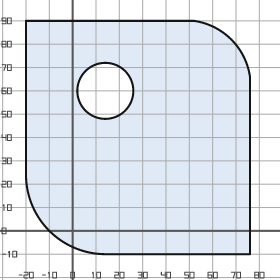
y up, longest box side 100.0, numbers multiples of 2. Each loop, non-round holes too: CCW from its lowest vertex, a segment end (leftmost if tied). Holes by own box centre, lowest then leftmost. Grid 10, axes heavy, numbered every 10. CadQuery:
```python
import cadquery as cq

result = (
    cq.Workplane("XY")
    .moveTo(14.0, -10.0)
    .lineTo(76.0, -10.0)
    .lineTo(76.0, 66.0)
    .threePointArc((68.0, 82.0), (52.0, 90.0))
    .lineTo(-20.0, 90.0)
    .lineTo(-20.0, 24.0)
    .threePointArc((-10.0, 0.0), (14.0, -10.0))
    .close()
    .moveTo(14.0, 60.0)
    .circle(12.0)
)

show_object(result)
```